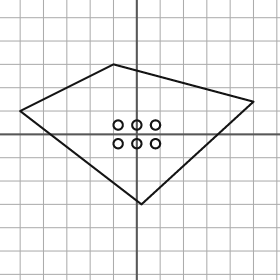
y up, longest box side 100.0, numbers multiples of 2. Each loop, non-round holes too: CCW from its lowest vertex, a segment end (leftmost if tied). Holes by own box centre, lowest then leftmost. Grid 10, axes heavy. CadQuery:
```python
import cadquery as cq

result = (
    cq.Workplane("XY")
    .moveTo(2.0, -30.0)
    .lineTo(50.0, 14.0)
    .lineTo(-10.0, 30.0)
    .lineTo(-50.0, 10.0)
    .close()
    .moveTo(-8.0, -4.0)
    .circle(2.0)
    .moveTo(0.0, -4.0)
    .circle(2.0)
    .moveTo(8.0, -4.0)
    .circle(2.0)
    .moveTo(-8.0, 4.0)
    .circle(2.0)
    .moveTo(0.0, 4.0)
    .circle(2.0)
    .moveTo(8.0, 4.0)
    .circle(2.0)
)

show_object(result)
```